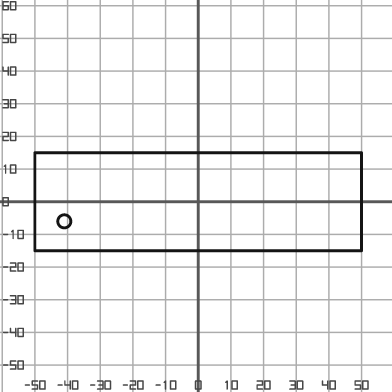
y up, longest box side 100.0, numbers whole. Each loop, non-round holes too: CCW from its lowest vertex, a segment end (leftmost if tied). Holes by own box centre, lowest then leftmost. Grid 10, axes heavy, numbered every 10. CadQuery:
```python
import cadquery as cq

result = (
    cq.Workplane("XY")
    .moveTo(-50.0, -15.0)
    .lineTo(50.0, -15.0)
    .lineTo(50.0, 15.0)
    .lineTo(-50.0, 15.0)
    .close()
    .moveTo(-41.0, -6.0)
    .circle(2.0)
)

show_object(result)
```